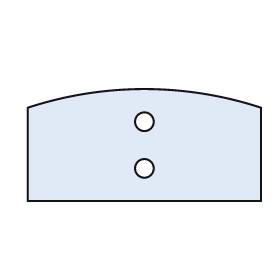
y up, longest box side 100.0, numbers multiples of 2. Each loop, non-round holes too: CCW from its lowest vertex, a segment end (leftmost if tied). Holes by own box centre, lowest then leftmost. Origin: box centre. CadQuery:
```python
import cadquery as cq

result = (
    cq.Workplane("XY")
    .moveTo(-50.0, -24.0)
    .lineTo(50.0, -24.0)
    .lineTo(50.0, 16.0)
    .threePointArc((0.0, 24.0), (-50.0, 16.0))
    .close()
    .moveTo(0.0, -10.0)
    .circle(4.0)
    .moveTo(0.0, 10.0)
    .circle(4.0)
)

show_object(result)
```